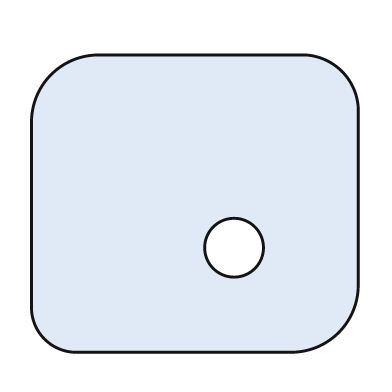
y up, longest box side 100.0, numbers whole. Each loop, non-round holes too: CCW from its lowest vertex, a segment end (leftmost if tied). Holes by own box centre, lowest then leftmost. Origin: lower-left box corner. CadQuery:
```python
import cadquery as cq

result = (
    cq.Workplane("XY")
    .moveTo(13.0, 0.0)
    .lineTo(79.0, 0.0)
    .threePointArc((94.0, 6.0), (100.0, 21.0))
    .lineTo(100.0, 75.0)
    .threePointArc((95.0, 86.0), (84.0, 91.0))
    .lineTo(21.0, 91.0)
    .threePointArc((6.0, 85.0), (0.0, 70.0))
    .lineTo(0.0, 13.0)
    .threePointArc((4.0, 4.0), (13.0, 0.0))
    .close()
    .moveTo(62.0, 32.0)
    .circle(9.0)
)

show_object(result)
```